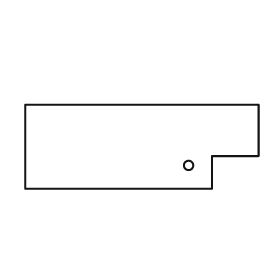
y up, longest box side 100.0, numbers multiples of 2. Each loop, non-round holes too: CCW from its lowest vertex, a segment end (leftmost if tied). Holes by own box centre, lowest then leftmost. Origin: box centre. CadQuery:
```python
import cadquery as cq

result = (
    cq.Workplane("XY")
    .moveTo(-50.0, -18.0)
    .lineTo(30.0, -18.0)
    .lineTo(30.0, -4.0)
    .lineTo(50.0, -4.0)
    .lineTo(50.0, 18.0)
    .lineTo(-50.0, 18.0)
    .close()
    .moveTo(20.0, -8.0)
    .circle(2.0)
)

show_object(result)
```